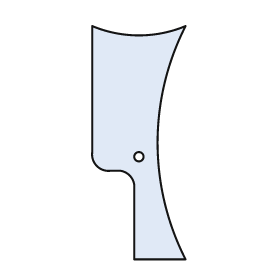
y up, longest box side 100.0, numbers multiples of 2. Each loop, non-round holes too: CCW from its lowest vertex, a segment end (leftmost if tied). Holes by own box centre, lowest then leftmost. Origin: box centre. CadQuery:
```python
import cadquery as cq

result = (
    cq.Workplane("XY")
    .moveTo(-2.0, -50.0)
    .lineTo(20.0, -50.0)
    .threePointArc((8.0, 0.0), (20.0, 50.0))
    .threePointArc((0.0, 46.0), (-20.0, 50.0))
    .lineTo(-20.0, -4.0)
    .threePointArc((-18.0, -10.0), (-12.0, -12.0))
    .lineTo(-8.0, -12.0)
    .threePointArc((-4.0, -14.0), (-2.0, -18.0))
    .close()
    .moveTo(0.0, -6.0)
    .circle(2.0)
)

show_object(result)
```